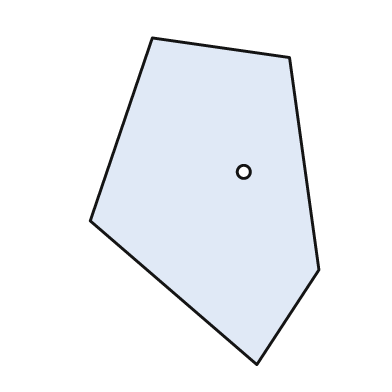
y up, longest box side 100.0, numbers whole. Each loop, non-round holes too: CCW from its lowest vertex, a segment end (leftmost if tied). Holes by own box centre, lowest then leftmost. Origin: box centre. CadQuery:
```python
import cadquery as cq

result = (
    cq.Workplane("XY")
    .moveTo(16.0, -50.0)
    .lineTo(35.0, -21.0)
    .lineTo(26.0, 44.0)
    .lineTo(-16.0, 50.0)
    .lineTo(-35.0, -6.0)
    .close()
    .moveTo(12.0, 9.0)
    .circle(2.0)
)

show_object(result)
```